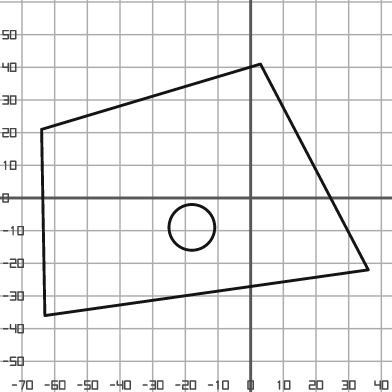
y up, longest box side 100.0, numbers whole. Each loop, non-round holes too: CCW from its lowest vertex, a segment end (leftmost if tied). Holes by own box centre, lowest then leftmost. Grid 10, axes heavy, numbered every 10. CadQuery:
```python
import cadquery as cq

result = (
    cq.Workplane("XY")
    .moveTo(-63.0, -36.0)
    .lineTo(36.0, -22.0)
    .lineTo(3.0, 41.0)
    .lineTo(-64.0, 21.0)
    .close()
    .moveTo(-18.0, -9.0)
    .circle(7.0)
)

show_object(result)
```